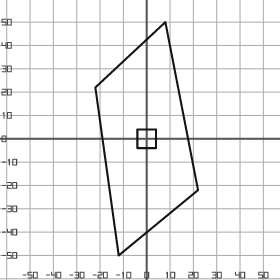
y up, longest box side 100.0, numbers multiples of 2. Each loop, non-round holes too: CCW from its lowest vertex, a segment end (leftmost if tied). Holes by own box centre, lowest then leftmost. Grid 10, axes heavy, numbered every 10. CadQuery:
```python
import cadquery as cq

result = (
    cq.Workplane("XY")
    .moveTo(-12.0, -50.0)
    .lineTo(22.0, -22.0)
    .lineTo(8.0, 50.0)
    .lineTo(-22.0, 22.0)
    .close()
    .moveTo(-4.0, -4.0)
    .lineTo(4.0, -4.0)
    .lineTo(4.0, 4.0)
    .lineTo(-4.0, 4.0)
    .close()
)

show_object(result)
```